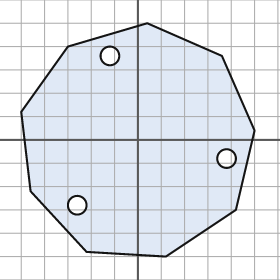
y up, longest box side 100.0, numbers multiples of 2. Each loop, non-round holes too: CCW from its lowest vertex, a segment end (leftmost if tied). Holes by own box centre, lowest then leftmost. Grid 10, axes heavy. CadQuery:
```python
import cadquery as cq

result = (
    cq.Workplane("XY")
    .moveTo(12.0, -50.0)
    .lineTo(42.0, -30.0)
    .lineTo(50.0, 4.0)
    .lineTo(36.0, 36.0)
    .lineTo(4.0, 50.0)
    .lineTo(-30.0, 40.0)
    .lineTo(-50.0, 12.0)
    .lineTo(-46.0, -22.0)
    .lineTo(-22.0, -48.0)
    .close()
    .moveTo(-26.0, -28.0)
    .circle(4.0)
    .moveTo(38.0, -8.0)
    .circle(4.0)
    .moveTo(-12.0, 36.0)
    .circle(4.0)
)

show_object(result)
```